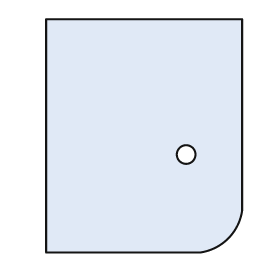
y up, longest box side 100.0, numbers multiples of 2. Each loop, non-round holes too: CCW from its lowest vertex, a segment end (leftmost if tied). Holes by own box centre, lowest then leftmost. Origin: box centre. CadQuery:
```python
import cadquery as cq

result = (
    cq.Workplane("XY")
    .moveTo(-42.0, -50.0)
    .lineTo(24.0, -50.0)
    .threePointArc((36.0, -44.0), (42.0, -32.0))
    .lineTo(42.0, 50.0)
    .lineTo(-42.0, 50.0)
    .close()
    .moveTo(18.0, -8.0)
    .circle(4.0)
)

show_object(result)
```